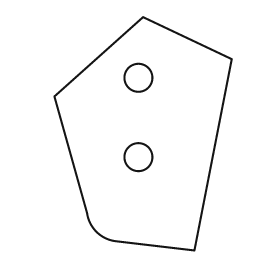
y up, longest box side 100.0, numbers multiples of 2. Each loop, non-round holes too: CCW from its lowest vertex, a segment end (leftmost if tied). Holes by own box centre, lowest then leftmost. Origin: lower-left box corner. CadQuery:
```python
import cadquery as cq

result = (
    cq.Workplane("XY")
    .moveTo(60.0, 0.0)
    .lineTo(76.0, 82.0)
    .lineTo(38.0, 100.0)
    .lineTo(0.0, 66.0)
    .lineTo(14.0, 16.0)
    .threePointArc((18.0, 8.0), (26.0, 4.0))
    .close()
    .moveTo(36.0, 40.0)
    .circle(6.0)
    .moveTo(36.0, 74.0)
    .circle(6.0)
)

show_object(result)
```